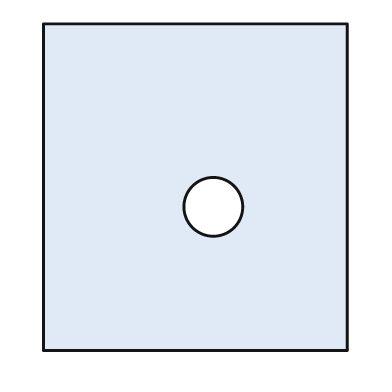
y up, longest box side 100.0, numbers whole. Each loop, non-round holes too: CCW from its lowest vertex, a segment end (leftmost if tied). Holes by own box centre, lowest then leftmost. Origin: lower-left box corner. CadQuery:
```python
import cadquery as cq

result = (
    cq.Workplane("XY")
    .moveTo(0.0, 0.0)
    .lineTo(93.0, 0.0)
    .lineTo(93.0, 100.0)
    .lineTo(0.0, 100.0)
    .close()
    .moveTo(52.0, 44.0)
    .circle(9.0)
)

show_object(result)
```